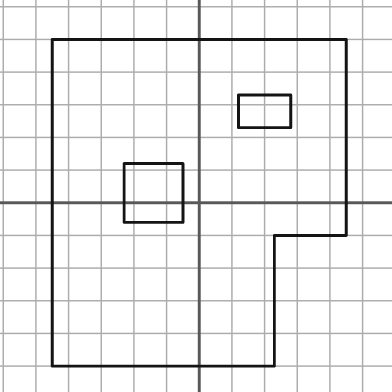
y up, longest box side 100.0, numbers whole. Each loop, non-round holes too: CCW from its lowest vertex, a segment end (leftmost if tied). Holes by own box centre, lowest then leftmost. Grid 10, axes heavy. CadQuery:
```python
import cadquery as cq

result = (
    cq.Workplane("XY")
    .moveTo(-45.0, -50.0)
    .lineTo(23.0, -50.0)
    .lineTo(23.0, -10.0)
    .lineTo(45.0, -10.0)
    .lineTo(45.0, 50.0)
    .lineTo(-45.0, 50.0)
    .close()
    .moveTo(-23.0, -6.0)
    .lineTo(-5.0, -6.0)
    .lineTo(-5.0, 12.0)
    .lineTo(-23.0, 12.0)
    .close()
    .moveTo(12.0, 23.0)
    .lineTo(28.0, 23.0)
    .lineTo(28.0, 33.0)
    .lineTo(12.0, 33.0)
    .close()
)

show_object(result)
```